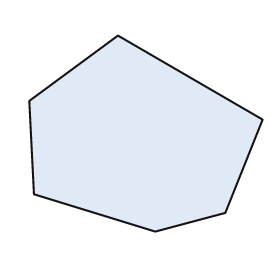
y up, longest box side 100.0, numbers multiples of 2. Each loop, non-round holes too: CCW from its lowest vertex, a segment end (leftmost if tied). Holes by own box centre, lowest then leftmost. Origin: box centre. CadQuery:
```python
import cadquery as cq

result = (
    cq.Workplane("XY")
    .moveTo(4.0, -42.0)
    .lineTo(34.0, -34.0)
    .lineTo(50.0, 6.0)
    .lineTo(-12.0, 42.0)
    .lineTo(-50.0, 14.0)
    .lineTo(-48.0, -26.0)
    .close()
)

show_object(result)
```